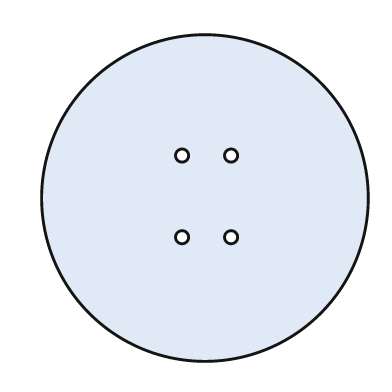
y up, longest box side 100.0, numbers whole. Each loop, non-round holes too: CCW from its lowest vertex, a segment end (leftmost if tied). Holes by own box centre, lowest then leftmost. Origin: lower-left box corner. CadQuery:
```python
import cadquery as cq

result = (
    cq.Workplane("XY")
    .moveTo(50.0, 50.0)
    .circle(50.0)
    .moveTo(43.0, 38.0)
    .circle(2.0)
    .moveTo(58.0, 38.0)
    .circle(2.0)
    .moveTo(43.0, 63.0)
    .circle(2.0)
    .moveTo(58.0, 63.0)
    .circle(2.0)
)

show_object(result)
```